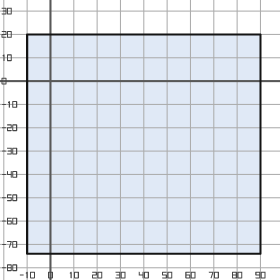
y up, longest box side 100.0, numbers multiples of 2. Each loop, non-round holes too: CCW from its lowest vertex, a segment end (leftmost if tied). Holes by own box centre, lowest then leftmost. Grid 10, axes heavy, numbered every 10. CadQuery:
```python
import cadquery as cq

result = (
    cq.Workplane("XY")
    .moveTo(-10.0, -74.0)
    .lineTo(90.0, -74.0)
    .lineTo(90.0, 20.0)
    .lineTo(-10.0, 20.0)
    .close()
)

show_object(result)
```